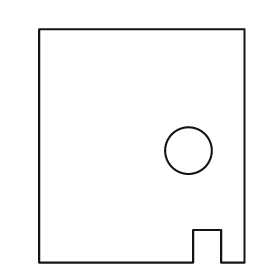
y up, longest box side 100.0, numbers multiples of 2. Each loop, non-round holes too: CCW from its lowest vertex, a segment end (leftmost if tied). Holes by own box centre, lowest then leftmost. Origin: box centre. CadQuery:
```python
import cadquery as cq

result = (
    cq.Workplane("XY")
    .moveTo(-44.0, -50.0)
    .lineTo(22.0, -50.0)
    .lineTo(22.0, -36.0)
    .lineTo(34.0, -36.0)
    .lineTo(34.0, -50.0)
    .lineTo(44.0, -50.0)
    .lineTo(44.0, 50.0)
    .lineTo(-44.0, 50.0)
    .close()
    .moveTo(20.0, -2.0)
    .circle(10.0)
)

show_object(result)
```